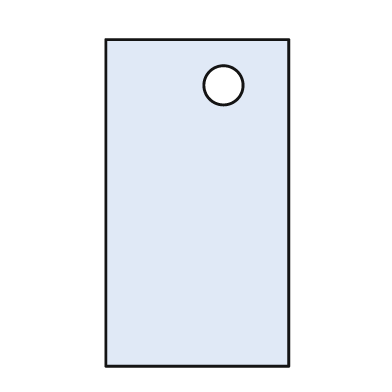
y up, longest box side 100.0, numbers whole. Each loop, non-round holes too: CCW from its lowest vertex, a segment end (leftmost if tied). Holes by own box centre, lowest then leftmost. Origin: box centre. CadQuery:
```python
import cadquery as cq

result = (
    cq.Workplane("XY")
    .moveTo(-28.0, -50.0)
    .lineTo(28.0, -50.0)
    .lineTo(28.0, 50.0)
    .lineTo(-28.0, 50.0)
    .close()
    .moveTo(8.0, 36.0)
    .circle(6.0)
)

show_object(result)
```